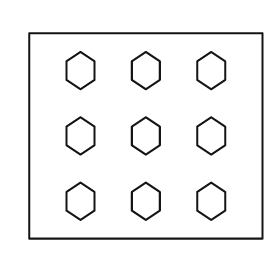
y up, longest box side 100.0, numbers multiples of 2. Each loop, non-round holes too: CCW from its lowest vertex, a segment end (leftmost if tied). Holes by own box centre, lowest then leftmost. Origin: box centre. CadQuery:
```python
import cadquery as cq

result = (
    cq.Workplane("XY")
    .moveTo(-50.0, -44.0)
    .lineTo(50.0, -44.0)
    .lineTo(50.0, 44.0)
    .lineTo(-50.0, 44.0)
    .close()
    .moveTo(-28.0, -36.0)
    .lineTo(-22.0, -32.0)
    .lineTo(-22.0, -24.0)
    .lineTo(-28.0, -20.0)
    .lineTo(-34.0, -24.0)
    .lineTo(-34.0, -32.0)
    .close()
    .moveTo(0.0, -36.0)
    .lineTo(6.0, -32.0)
    .lineTo(6.0, -24.0)
    .lineTo(0.0, -20.0)
    .lineTo(-6.0, -24.0)
    .lineTo(-6.0, -32.0)
    .close()
    .moveTo(28.0, -36.0)
    .lineTo(34.0, -32.0)
    .lineTo(34.0, -24.0)
    .lineTo(28.0, -20.0)
    .lineTo(22.0, -24.0)
    .lineTo(22.0, -32.0)
    .close()
    .moveTo(-28.0, -8.0)
    .lineTo(-22.0, -4.0)
    .lineTo(-22.0, 4.0)
    .lineTo(-28.0, 8.0)
    .lineTo(-34.0, 4.0)
    .lineTo(-34.0, -4.0)
    .close()
    .moveTo(0.0, -8.0)
    .lineTo(6.0, -4.0)
    .lineTo(6.0, 4.0)
    .lineTo(0.0, 8.0)
    .lineTo(-6.0, 4.0)
    .lineTo(-6.0, -4.0)
    .close()
    .moveTo(28.0, -8.0)
    .lineTo(34.0, -4.0)
    .lineTo(34.0, 4.0)
    .lineTo(28.0, 8.0)
    .lineTo(22.0, 4.0)
    .lineTo(22.0, -4.0)
    .close()
    .moveTo(-28.0, 20.0)
    .lineTo(-22.0, 24.0)
    .lineTo(-22.0, 32.0)
    .lineTo(-28.0, 36.0)
    .lineTo(-34.0, 32.0)
    .lineTo(-34.0, 24.0)
    .close()
    .moveTo(0.0, 20.0)
    .lineTo(6.0, 24.0)
    .lineTo(6.0, 32.0)
    .lineTo(0.0, 36.0)
    .lineTo(-6.0, 32.0)
    .lineTo(-6.0, 24.0)
    .close()
    .moveTo(28.0, 20.0)
    .lineTo(34.0, 24.0)
    .lineTo(34.0, 32.0)
    .lineTo(28.0, 36.0)
    .lineTo(22.0, 32.0)
    .lineTo(22.0, 24.0)
    .close()
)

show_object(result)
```